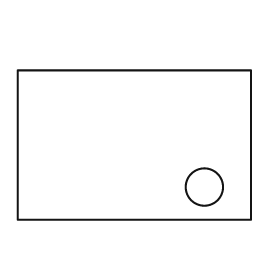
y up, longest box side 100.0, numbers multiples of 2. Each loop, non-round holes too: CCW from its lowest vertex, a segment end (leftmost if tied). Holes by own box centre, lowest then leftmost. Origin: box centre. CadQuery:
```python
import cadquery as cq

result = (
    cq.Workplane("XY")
    .moveTo(-50.0, -32.0)
    .lineTo(50.0, -32.0)
    .lineTo(50.0, 32.0)
    .lineTo(-50.0, 32.0)
    .close()
    .moveTo(30.0, -18.0)
    .circle(8.0)
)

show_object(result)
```